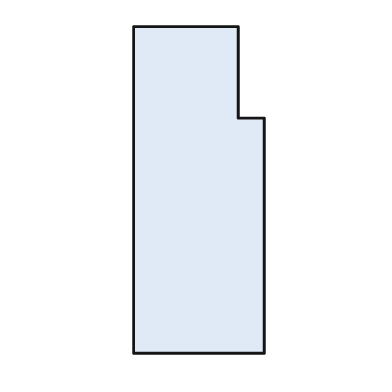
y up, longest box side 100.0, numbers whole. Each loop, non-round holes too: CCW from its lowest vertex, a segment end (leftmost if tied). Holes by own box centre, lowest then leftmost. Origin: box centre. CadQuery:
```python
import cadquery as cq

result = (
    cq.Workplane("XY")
    .moveTo(-20.0, -50.0)
    .lineTo(20.0, -50.0)
    .lineTo(20.0, 22.0)
    .lineTo(12.0, 22.0)
    .lineTo(12.0, 50.0)
    .lineTo(-20.0, 50.0)
    .close()
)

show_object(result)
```